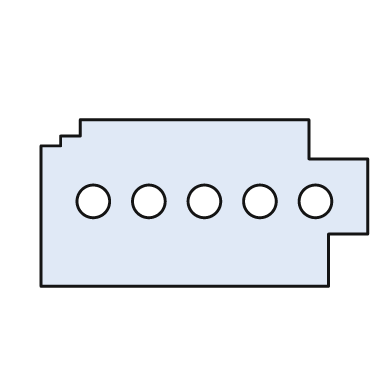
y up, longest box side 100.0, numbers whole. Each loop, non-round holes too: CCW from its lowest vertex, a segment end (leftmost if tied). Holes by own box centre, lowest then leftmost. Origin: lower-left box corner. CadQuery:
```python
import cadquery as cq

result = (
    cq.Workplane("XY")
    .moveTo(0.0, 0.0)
    .lineTo(88.0, 0.0)
    .lineTo(88.0, 16.0)
    .lineTo(100.0, 16.0)
    .lineTo(100.0, 39.0)
    .lineTo(82.0, 39.0)
    .lineTo(82.0, 51.0)
    .lineTo(12.0, 51.0)
    .lineTo(12.0, 46.0)
    .lineTo(6.0, 46.0)
    .lineTo(6.0, 43.0)
    .lineTo(0.0, 43.0)
    .close()
    .moveTo(16.0, 26.0)
    .circle(5.0)
    .moveTo(33.0, 26.0)
    .circle(5.0)
    .moveTo(50.0, 26.0)
    .circle(5.0)
    .moveTo(67.0, 26.0)
    .circle(5.0)
    .moveTo(84.0, 26.0)
    .circle(5.0)
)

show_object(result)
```